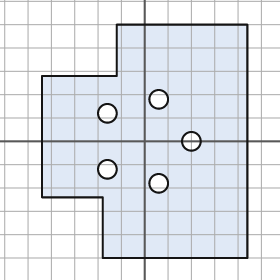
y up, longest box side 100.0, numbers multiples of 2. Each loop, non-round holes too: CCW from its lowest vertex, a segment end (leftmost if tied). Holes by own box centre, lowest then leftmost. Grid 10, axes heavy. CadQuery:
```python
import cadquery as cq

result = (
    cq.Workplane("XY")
    .moveTo(-18.0, -50.0)
    .lineTo(44.0, -50.0)
    .lineTo(44.0, 50.0)
    .lineTo(-12.0, 50.0)
    .lineTo(-12.0, 28.0)
    .lineTo(-44.0, 28.0)
    .lineTo(-44.0, -24.0)
    .lineTo(-18.0, -24.0)
    .close()
    .moveTo(6.0, -18.0)
    .circle(4.0)
    .moveTo(-16.0, -12.0)
    .circle(4.0)
    .moveTo(20.0, 0.0)
    .circle(4.0)
    .moveTo(-16.0, 12.0)
    .circle(4.0)
    .moveTo(6.0, 18.0)
    .circle(4.0)
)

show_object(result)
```